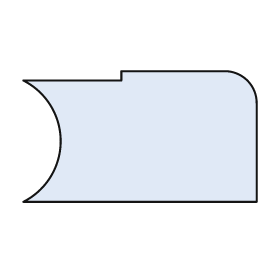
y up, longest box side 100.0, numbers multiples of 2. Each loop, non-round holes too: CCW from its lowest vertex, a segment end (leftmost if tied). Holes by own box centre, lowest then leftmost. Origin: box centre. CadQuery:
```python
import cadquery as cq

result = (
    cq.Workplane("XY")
    .moveTo(-50.0, -28.0)
    .lineTo(50.0, -28.0)
    .lineTo(50.0, 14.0)
    .threePointArc((46.0, 24.0), (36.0, 28.0))
    .lineTo(-8.0, 28.0)
    .lineTo(-8.0, 24.0)
    .lineTo(-50.0, 24.0)
    .threePointArc((-34.0, -2.0), (-50.0, -28.0))
    .close()
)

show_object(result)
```